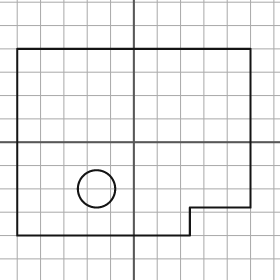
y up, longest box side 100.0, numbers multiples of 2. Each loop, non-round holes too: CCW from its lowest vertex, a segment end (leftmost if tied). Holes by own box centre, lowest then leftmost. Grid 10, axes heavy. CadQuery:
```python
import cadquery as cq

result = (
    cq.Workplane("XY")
    .moveTo(-50.0, -40.0)
    .lineTo(24.0, -40.0)
    .lineTo(24.0, -28.0)
    .lineTo(50.0, -28.0)
    .lineTo(50.0, 40.0)
    .lineTo(-50.0, 40.0)
    .close()
    .moveTo(-16.0, -20.0)
    .circle(8.0)
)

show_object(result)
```